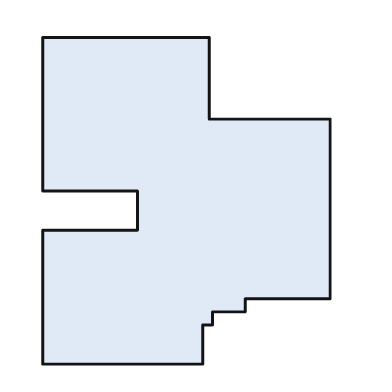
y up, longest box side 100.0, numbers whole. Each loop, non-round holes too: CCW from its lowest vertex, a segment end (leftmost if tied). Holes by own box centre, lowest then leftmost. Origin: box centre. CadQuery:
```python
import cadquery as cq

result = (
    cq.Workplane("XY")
    .moveTo(-44.0, -50.0)
    .lineTo(5.0, -50.0)
    .lineTo(5.0, -38.0)
    .lineTo(8.0, -38.0)
    .lineTo(8.0, -34.0)
    .lineTo(18.0, -34.0)
    .lineTo(18.0, -30.0)
    .lineTo(44.0, -30.0)
    .lineTo(44.0, 25.0)
    .lineTo(7.0, 25.0)
    .lineTo(7.0, 50.0)
    .lineTo(-44.0, 50.0)
    .lineTo(-44.0, 3.0)
    .lineTo(-15.0, 3.0)
    .lineTo(-15.0, -9.0)
    .lineTo(-44.0, -9.0)
    .close()
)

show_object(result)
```